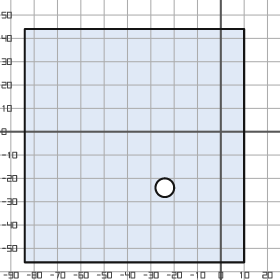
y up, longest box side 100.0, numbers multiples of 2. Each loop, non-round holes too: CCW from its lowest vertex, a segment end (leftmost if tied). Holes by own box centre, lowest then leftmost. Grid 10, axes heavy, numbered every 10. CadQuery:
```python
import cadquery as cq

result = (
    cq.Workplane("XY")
    .moveTo(-84.0, -56.0)
    .lineTo(10.0, -56.0)
    .lineTo(10.0, 44.0)
    .lineTo(-84.0, 44.0)
    .close()
    .moveTo(-24.0, -24.0)
    .circle(4.0)
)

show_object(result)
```